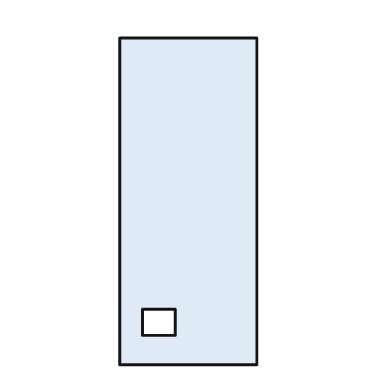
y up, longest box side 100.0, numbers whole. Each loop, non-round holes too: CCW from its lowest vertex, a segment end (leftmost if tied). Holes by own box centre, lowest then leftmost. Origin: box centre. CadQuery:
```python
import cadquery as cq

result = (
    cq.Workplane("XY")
    .moveTo(-21.0, -50.0)
    .lineTo(21.0, -50.0)
    .lineTo(21.0, 50.0)
    .lineTo(-21.0, 50.0)
    .close()
    .moveTo(-14.0, -41.0)
    .lineTo(-4.0, -41.0)
    .lineTo(-4.0, -33.0)
    .lineTo(-14.0, -33.0)
    .close()
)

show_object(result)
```